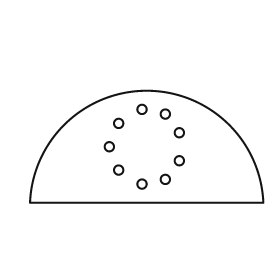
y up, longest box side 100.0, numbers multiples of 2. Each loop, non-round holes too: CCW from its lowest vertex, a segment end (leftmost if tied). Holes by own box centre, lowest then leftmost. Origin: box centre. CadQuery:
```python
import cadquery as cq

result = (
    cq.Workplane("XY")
    .moveTo(-50.0, -24.0)
    .lineTo(50.0, -24.0)
    .threePointArc((0.0, 24.0), (-50.0, -24.0))
    .close()
    .moveTo(-2.0, -16.0)
    .circle(2.0)
    .moveTo(8.0, -14.0)
    .circle(2.0)
    .moveTo(-12.0, -10.0)
    .circle(2.0)
    .moveTo(14.0, -6.0)
    .circle(2.0)
    .moveTo(-16.0, 0.0)
    .circle(2.0)
    .moveTo(14.0, 6.0)
    .circle(2.0)
    .moveTo(-12.0, 10.0)
    .circle(2.0)
    .moveTo(8.0, 14.0)
    .circle(2.0)
    .moveTo(-2.0, 16.0)
    .circle(2.0)
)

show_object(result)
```